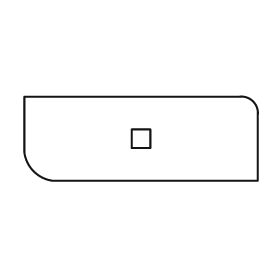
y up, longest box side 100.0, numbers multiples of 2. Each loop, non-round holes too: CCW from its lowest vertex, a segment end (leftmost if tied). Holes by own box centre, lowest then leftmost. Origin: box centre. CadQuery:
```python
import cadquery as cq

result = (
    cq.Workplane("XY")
    .moveTo(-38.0, -18.0)
    .lineTo(50.0, -18.0)
    .lineTo(50.0, 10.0)
    .threePointArc((48.0, 16.0), (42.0, 18.0))
    .lineTo(-50.0, 18.0)
    .lineTo(-50.0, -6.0)
    .threePointArc((-46.0, -14.0), (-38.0, -18.0))
    .close()
    .moveTo(-4.0, -4.0)
    .lineTo(4.0, -4.0)
    .lineTo(4.0, 4.0)
    .lineTo(-4.0, 4.0)
    .close()
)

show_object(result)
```